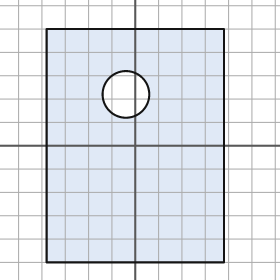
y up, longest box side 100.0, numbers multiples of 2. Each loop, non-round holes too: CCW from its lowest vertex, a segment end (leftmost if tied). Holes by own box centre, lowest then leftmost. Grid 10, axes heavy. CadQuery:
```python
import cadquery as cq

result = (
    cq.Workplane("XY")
    .moveTo(-38.0, -50.0)
    .lineTo(38.0, -50.0)
    .lineTo(38.0, 50.0)
    .lineTo(-38.0, 50.0)
    .close()
    .moveTo(-4.0, 22.0)
    .circle(10.0)
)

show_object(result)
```